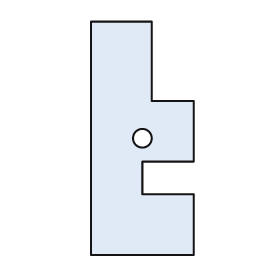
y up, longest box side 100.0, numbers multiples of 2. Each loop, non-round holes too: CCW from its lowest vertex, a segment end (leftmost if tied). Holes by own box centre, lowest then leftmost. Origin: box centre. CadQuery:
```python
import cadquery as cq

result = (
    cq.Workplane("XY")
    .moveTo(-22.0, -50.0)
    .lineTo(22.0, -50.0)
    .lineTo(22.0, -24.0)
    .lineTo(0.0, -24.0)
    .lineTo(0.0, -10.0)
    .lineTo(22.0, -10.0)
    .lineTo(22.0, 16.0)
    .lineTo(4.0, 16.0)
    .lineTo(4.0, 50.0)
    .lineTo(-22.0, 50.0)
    .close()
    .moveTo(0.0, 0.0)
    .circle(4.0)
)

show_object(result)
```